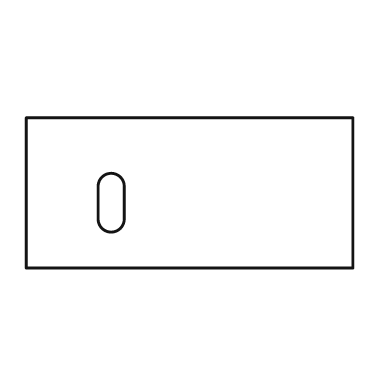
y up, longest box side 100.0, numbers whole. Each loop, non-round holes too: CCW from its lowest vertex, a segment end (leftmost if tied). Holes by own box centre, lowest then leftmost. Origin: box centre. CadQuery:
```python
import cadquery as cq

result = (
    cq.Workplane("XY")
    .moveTo(-50.0, -23.0)
    .lineTo(50.0, -23.0)
    .lineTo(50.0, 23.0)
    .lineTo(-50.0, 23.0)
    .close()
    .moveTo(-28.0, -8.0)
    .threePointArc((-24.0, -12.0), (-20.0, -8.0))
    .lineTo(-20.0, 2.0)
    .threePointArc((-24.0, 6.0), (-28.0, 2.0))
    .close()
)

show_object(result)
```